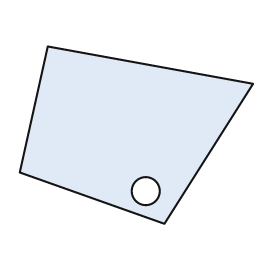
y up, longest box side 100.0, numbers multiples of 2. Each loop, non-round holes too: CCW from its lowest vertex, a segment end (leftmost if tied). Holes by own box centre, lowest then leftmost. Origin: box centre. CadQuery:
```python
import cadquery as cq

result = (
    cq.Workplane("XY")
    .moveTo(12.0, -38.0)
    .lineTo(50.0, 22.0)
    .lineTo(-38.0, 38.0)
    .lineTo(-50.0, -16.0)
    .close()
    .moveTo(4.0, -24.0)
    .circle(6.0)
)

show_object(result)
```